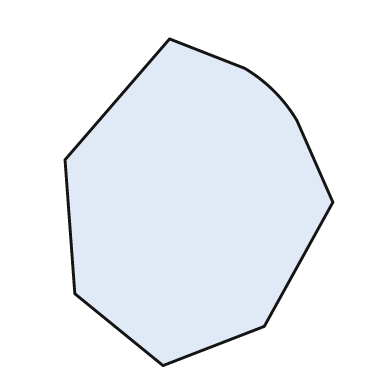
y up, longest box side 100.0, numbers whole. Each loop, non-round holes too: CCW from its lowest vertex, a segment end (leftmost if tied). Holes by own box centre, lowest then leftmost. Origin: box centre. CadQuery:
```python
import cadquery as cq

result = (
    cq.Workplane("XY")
    .moveTo(-11.0, -50.0)
    .lineTo(20.0, -38.0)
    .lineTo(41.0, 0.0)
    .lineTo(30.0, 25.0)
    .threePointArc((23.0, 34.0), (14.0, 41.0))
    .lineTo(-9.0, 50.0)
    .lineTo(-41.0, 13.0)
    .lineTo(-38.0, -28.0)
    .close()
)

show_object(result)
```